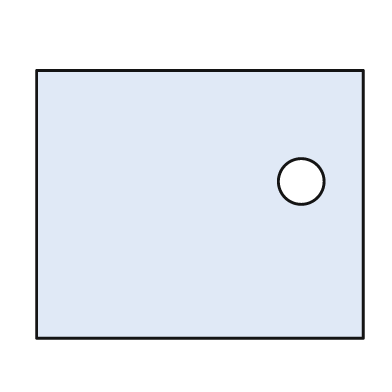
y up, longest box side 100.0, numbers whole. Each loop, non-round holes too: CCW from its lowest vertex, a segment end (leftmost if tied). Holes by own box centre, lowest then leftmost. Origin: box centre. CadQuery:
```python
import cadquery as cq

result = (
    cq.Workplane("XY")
    .moveTo(-50.0, -41.0)
    .lineTo(50.0, -41.0)
    .lineTo(50.0, 41.0)
    .lineTo(-50.0, 41.0)
    .close()
    .moveTo(31.0, 7.0)
    .circle(7.0)
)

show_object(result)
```